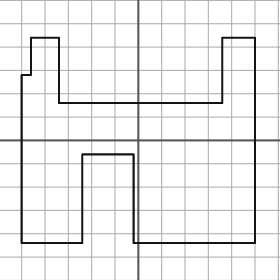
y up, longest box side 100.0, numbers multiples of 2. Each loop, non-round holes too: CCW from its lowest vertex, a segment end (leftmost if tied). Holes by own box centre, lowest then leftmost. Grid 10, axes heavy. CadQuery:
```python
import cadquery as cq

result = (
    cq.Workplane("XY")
    .moveTo(-50.0, -44.0)
    .lineTo(-24.0, -44.0)
    .lineTo(-24.0, -6.0)
    .lineTo(-2.0, -6.0)
    .lineTo(-2.0, -44.0)
    .lineTo(50.0, -44.0)
    .lineTo(50.0, 44.0)
    .lineTo(36.0, 44.0)
    .lineTo(36.0, 16.0)
    .lineTo(-34.0, 16.0)
    .lineTo(-34.0, 44.0)
    .lineTo(-46.0, 44.0)
    .lineTo(-46.0, 28.0)
    .lineTo(-50.0, 28.0)
    .close()
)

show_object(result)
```